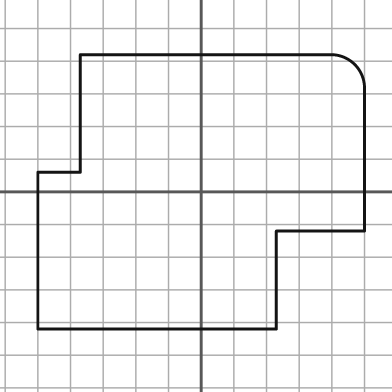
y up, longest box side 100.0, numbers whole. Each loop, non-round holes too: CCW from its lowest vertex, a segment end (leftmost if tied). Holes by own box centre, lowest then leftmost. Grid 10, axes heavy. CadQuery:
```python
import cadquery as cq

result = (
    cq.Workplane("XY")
    .moveTo(-50.0, -42.0)
    .lineTo(23.0, -42.0)
    .lineTo(23.0, -12.0)
    .lineTo(50.0, -12.0)
    .lineTo(50.0, 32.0)
    .threePointArc((47.0, 39.0), (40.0, 42.0))
    .lineTo(-37.0, 42.0)
    .lineTo(-37.0, 6.0)
    .lineTo(-50.0, 6.0)
    .close()
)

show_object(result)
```